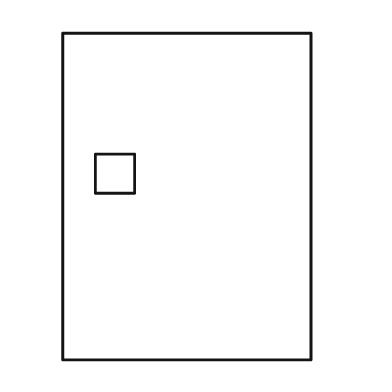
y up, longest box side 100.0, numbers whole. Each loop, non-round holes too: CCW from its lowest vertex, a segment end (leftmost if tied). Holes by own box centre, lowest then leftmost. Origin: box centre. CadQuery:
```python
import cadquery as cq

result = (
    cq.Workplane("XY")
    .moveTo(-38.0, -50.0)
    .lineTo(38.0, -50.0)
    .lineTo(38.0, 50.0)
    .lineTo(-38.0, 50.0)
    .close()
    .moveTo(-28.0, 1.0)
    .lineTo(-16.0, 1.0)
    .lineTo(-16.0, 13.0)
    .lineTo(-28.0, 13.0)
    .close()
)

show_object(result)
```